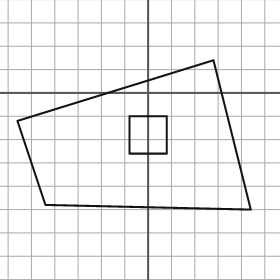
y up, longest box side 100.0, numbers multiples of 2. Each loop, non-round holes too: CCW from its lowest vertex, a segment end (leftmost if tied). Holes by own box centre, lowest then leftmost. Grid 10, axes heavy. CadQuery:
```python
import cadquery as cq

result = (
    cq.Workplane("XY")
    .moveTo(44.0, -50.0)
    .lineTo(28.0, 14.0)
    .lineTo(-56.0, -12.0)
    .lineTo(-44.0, -48.0)
    .close()
    .moveTo(-8.0, -26.0)
    .lineTo(8.0, -26.0)
    .lineTo(8.0, -10.0)
    .lineTo(-8.0, -10.0)
    .close()
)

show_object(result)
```